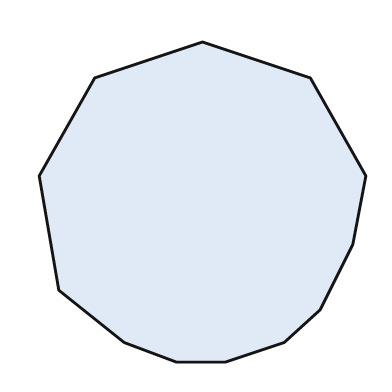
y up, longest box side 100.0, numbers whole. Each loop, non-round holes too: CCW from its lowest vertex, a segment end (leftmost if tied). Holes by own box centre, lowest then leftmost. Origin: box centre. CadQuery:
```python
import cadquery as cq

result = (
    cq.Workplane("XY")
    .moveTo(-8.0, -49.0)
    .lineTo(7.0, -49.0)
    .lineTo(25.0, -43.0)
    .lineTo(36.0, -33.0)
    .lineTo(46.0, -13.0)
    .lineTo(50.0, 8.0)
    .lineTo(33.0, 38.0)
    .lineTo(0.0, 49.0)
    .lineTo(-33.0, 38.0)
    .lineTo(-50.0, 8.0)
    .lineTo(-44.0, -27.0)
    .lineTo(-24.0, -43.0)
    .close()
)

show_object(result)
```